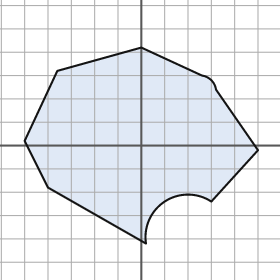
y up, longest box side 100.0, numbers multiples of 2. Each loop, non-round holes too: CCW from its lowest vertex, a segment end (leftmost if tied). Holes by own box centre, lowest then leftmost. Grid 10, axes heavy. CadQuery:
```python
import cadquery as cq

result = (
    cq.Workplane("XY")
    .moveTo(2.0, -42.0)
    .threePointArc((10.0, -24.0), (30.0, -24.0))
    .lineTo(50.0, -2.0)
    .lineTo(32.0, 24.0)
    .threePointArc((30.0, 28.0), (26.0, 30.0))
    .lineTo(0.0, 42.0)
    .lineTo(-36.0, 32.0)
    .lineTo(-50.0, 2.0)
    .lineTo(-40.0, -18.0)
    .close()
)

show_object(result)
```